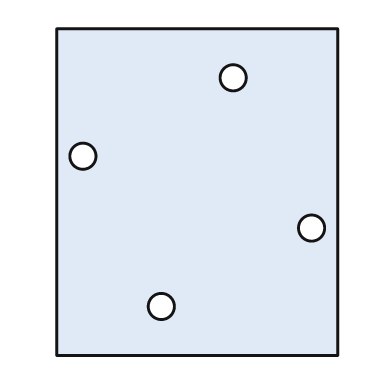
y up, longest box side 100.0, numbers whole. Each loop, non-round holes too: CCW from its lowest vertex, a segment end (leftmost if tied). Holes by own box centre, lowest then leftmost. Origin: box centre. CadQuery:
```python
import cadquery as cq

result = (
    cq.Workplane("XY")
    .moveTo(-43.0, -50.0)
    .lineTo(43.0, -50.0)
    .lineTo(43.0, 50.0)
    .lineTo(-43.0, 50.0)
    .close()
    .moveTo(-11.0, -35.0)
    .circle(4.0)
    .moveTo(35.0, -11.0)
    .circle(4.0)
    .moveTo(-35.0, 11.0)
    .circle(4.0)
    .moveTo(11.0, 35.0)
    .circle(4.0)
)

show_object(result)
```